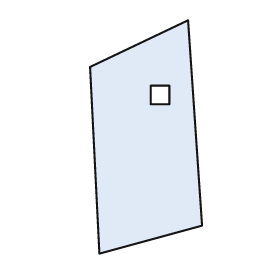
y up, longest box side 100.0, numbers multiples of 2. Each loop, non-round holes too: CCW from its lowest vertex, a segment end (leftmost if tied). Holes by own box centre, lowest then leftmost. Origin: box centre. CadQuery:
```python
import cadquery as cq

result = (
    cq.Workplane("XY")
    .moveTo(-20.0, -50.0)
    .lineTo(24.0, -38.0)
    .lineTo(18.0, 50.0)
    .lineTo(-24.0, 30.0)
    .close()
    .moveTo(2.0, 14.0)
    .lineTo(10.0, 14.0)
    .lineTo(10.0, 22.0)
    .lineTo(2.0, 22.0)
    .close()
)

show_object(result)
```